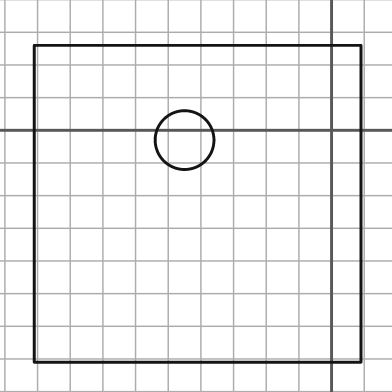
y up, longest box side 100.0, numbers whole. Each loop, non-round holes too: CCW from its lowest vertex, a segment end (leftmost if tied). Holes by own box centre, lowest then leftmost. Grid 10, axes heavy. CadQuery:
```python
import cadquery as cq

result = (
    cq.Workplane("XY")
    .moveTo(-91.0, -71.0)
    .lineTo(9.0, -71.0)
    .lineTo(9.0, 26.0)
    .lineTo(-91.0, 26.0)
    .close()
    .moveTo(-45.0, -3.0)
    .circle(9.0)
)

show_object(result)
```